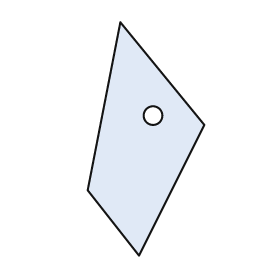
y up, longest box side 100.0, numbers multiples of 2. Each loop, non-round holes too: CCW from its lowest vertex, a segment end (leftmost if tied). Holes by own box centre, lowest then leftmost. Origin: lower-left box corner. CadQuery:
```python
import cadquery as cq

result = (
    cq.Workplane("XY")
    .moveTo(22.0, 0.0)
    .lineTo(50.0, 56.0)
    .lineTo(14.0, 100.0)
    .lineTo(0.0, 28.0)
    .close()
    .moveTo(28.0, 60.0)
    .circle(4.0)
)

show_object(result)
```